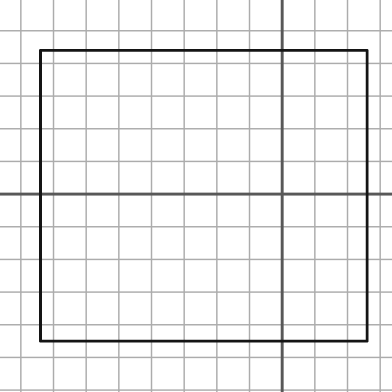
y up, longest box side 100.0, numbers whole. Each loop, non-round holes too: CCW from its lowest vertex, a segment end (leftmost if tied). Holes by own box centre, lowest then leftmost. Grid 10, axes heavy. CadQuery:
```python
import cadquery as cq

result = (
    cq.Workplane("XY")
    .moveTo(-74.0, -45.0)
    .lineTo(26.0, -45.0)
    .lineTo(26.0, 44.0)
    .lineTo(-74.0, 44.0)
    .close()
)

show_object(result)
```